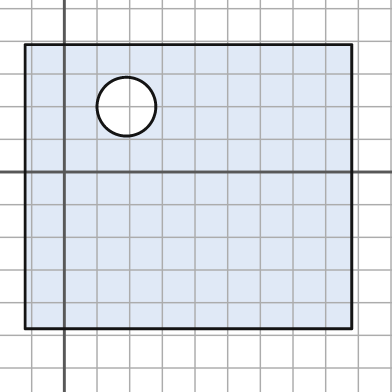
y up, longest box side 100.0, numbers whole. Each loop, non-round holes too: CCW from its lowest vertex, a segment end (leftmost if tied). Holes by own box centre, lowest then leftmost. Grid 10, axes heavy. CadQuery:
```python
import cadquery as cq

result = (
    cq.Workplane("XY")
    .moveTo(-12.0, -48.0)
    .lineTo(88.0, -48.0)
    .lineTo(88.0, 39.0)
    .lineTo(-12.0, 39.0)
    .close()
    .moveTo(19.0, 20.0)
    .circle(9.0)
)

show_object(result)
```